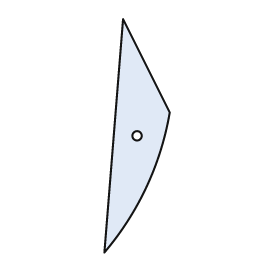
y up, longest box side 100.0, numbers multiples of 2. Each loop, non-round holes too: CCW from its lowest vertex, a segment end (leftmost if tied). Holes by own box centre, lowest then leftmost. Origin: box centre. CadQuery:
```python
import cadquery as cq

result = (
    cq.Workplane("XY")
    .moveTo(-14.0, -50.0)
    .threePointArc((4.0, -22.0), (14.0, 10.0))
    .lineTo(-6.0, 50.0)
    .close()
    .moveTo(0.0, 0.0)
    .circle(2.0)
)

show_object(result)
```